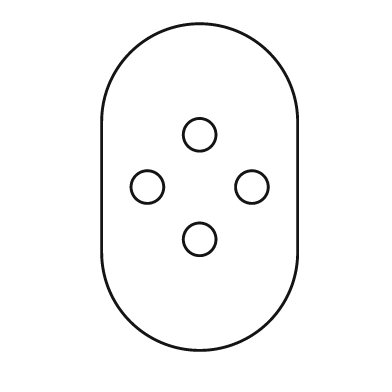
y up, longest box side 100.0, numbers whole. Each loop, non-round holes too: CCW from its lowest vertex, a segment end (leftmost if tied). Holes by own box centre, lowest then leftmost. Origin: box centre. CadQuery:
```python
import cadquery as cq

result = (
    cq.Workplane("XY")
    .moveTo(-30.0, -20.0)
    .threePointArc((0.0, -50.0), (30.0, -20.0))
    .lineTo(30.0, 20.0)
    .threePointArc((0.0, 50.0), (-30.0, 20.0))
    .close()
    .moveTo(0.0, -16.0)
    .circle(5.0)
    .moveTo(-16.0, 0.0)
    .circle(5.0)
    .moveTo(16.0, 0.0)
    .circle(5.0)
    .moveTo(0.0, 16.0)
    .circle(5.0)
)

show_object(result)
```